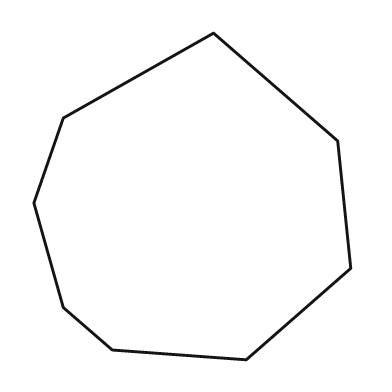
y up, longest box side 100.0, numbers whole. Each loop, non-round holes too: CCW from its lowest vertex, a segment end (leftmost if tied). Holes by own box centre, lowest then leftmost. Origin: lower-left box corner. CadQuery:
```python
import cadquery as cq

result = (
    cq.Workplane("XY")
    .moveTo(65.0, 0.0)
    .lineTo(97.0, 28.0)
    .lineTo(93.0, 67.0)
    .lineTo(55.0, 100.0)
    .lineTo(9.0, 74.0)
    .lineTo(0.0, 48.0)
    .lineTo(9.0, 16.0)
    .lineTo(24.0, 3.0)
    .close()
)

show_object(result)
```